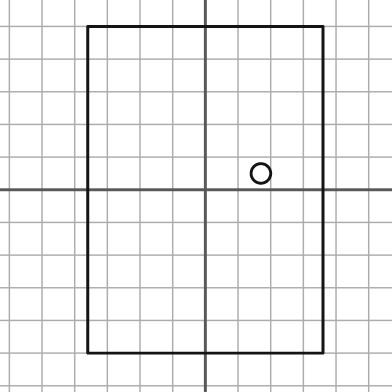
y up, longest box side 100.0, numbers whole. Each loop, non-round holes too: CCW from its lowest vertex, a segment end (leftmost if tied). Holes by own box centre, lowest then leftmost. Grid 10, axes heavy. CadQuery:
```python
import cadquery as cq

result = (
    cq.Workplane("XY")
    .moveTo(-36.0, -50.0)
    .lineTo(36.0, -50.0)
    .lineTo(36.0, 50.0)
    .lineTo(-36.0, 50.0)
    .close()
    .moveTo(17.0, 5.0)
    .circle(3.0)
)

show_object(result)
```